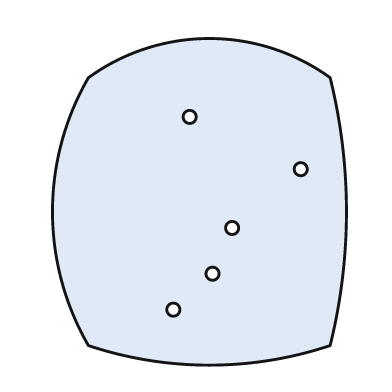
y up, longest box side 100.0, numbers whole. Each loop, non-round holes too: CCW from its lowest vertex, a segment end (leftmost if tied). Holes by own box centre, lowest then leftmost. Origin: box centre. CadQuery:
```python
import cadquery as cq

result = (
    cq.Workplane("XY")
    .moveTo(-34.0, -44.0)
    .threePointArc((3.0, -50.0), (40.0, -44.0))
    .threePointArc((45.0, -3.0), (40.0, 38.0))
    .threePointArc((3.0, 50.0), (-34.0, 38.0))
    .threePointArc((-45.0, -3.0), (-34.0, -44.0))
    .close()
    .moveTo(-8.0, -33.0)
    .circle(2.0)
    .moveTo(4.0, -22.0)
    .circle(2.0)
    .moveTo(10.0, -8.0)
    .circle(2.0)
    .moveTo(31.0, 10.0)
    .circle(2.0)
    .moveTo(-3.0, 26.0)
    .circle(2.0)
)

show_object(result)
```